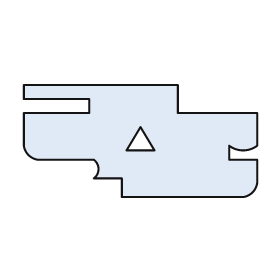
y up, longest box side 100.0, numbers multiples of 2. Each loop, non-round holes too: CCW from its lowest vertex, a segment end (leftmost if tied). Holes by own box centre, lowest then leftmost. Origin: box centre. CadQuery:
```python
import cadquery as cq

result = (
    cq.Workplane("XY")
    .moveTo(-8.0, -24.0)
    .lineTo(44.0, -24.0)
    .threePointArc((48.0, -22.0), (50.0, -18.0))
    .lineTo(50.0, -8.0)
    .lineTo(38.0, -8.0)
    .lineTo(38.0, -2.0)
    .threePointArc((44.0, -4.0), (50.0, -2.0))
    .lineTo(50.0, 12.0)
    .lineTo(16.0, 12.0)
    .lineTo(16.0, 24.0)
    .lineTo(-50.0, 24.0)
    .lineTo(-50.0, 18.0)
    .lineTo(-22.0, 18.0)
    .lineTo(-22.0, 12.0)
    .lineTo(-50.0, 12.0)
    .lineTo(-50.0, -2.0)
    .threePointArc((-48.0, -6.0), (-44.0, -8.0))
    .lineTo(-20.0, -8.0)
    .threePointArc((-18.0, -12.0), (-20.0, -16.0))
    .lineTo(-8.0, -16.0)
    .close()
    .moveTo(-6.0, -4.0)
    .lineTo(6.0, -4.0)
    .lineTo(0.0, 6.0)
    .close()
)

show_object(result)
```